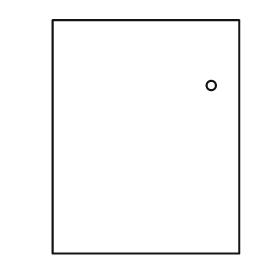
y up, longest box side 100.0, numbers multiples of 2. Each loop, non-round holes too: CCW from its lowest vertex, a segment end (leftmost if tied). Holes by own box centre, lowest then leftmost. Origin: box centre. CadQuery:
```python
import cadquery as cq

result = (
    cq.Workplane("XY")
    .moveTo(-40.0, -50.0)
    .lineTo(40.0, -50.0)
    .lineTo(40.0, 50.0)
    .lineTo(-40.0, 50.0)
    .close()
    .moveTo(28.0, 22.0)
    .circle(2.0)
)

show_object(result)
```